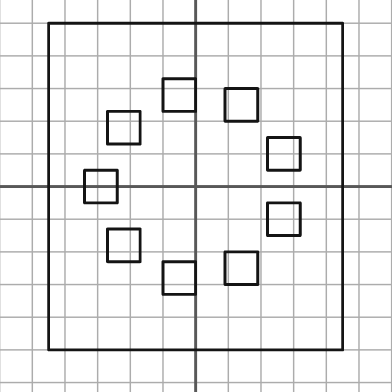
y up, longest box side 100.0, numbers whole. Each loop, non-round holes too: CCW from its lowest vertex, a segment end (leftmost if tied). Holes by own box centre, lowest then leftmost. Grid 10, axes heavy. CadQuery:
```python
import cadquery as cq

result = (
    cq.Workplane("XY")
    .moveTo(-45.0, -50.0)
    .lineTo(45.0, -50.0)
    .lineTo(45.0, 50.0)
    .lineTo(-45.0, 50.0)
    .close()
    .moveTo(-10.0, -33.0)
    .lineTo(0.0, -33.0)
    .lineTo(0.0, -23.0)
    .lineTo(-10.0, -23.0)
    .close()
    .moveTo(9.0, -30.0)
    .lineTo(19.0, -30.0)
    .lineTo(19.0, -20.0)
    .lineTo(9.0, -20.0)
    .close()
    .moveTo(-27.0, -23.0)
    .lineTo(-17.0, -23.0)
    .lineTo(-17.0, -13.0)
    .lineTo(-27.0, -13.0)
    .close()
    .moveTo(22.0, -15.0)
    .lineTo(32.0, -15.0)
    .lineTo(32.0, -5.0)
    .lineTo(22.0, -5.0)
    .close()
    .moveTo(-34.0, -5.0)
    .lineTo(-24.0, -5.0)
    .lineTo(-24.0, 5.0)
    .lineTo(-34.0, 5.0)
    .close()
    .moveTo(22.0, 5.0)
    .lineTo(32.0, 5.0)
    .lineTo(32.0, 15.0)
    .lineTo(22.0, 15.0)
    .close()
    .moveTo(-27.0, 13.0)
    .lineTo(-17.0, 13.0)
    .lineTo(-17.0, 23.0)
    .lineTo(-27.0, 23.0)
    .close()
    .moveTo(9.0, 20.0)
    .lineTo(19.0, 20.0)
    .lineTo(19.0, 30.0)
    .lineTo(9.0, 30.0)
    .close()
    .moveTo(-10.0, 23.0)
    .lineTo(0.0, 23.0)
    .lineTo(0.0, 33.0)
    .lineTo(-10.0, 33.0)
    .close()
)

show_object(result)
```